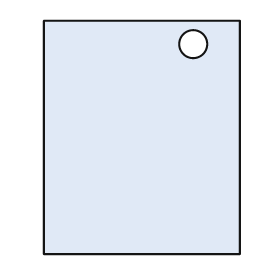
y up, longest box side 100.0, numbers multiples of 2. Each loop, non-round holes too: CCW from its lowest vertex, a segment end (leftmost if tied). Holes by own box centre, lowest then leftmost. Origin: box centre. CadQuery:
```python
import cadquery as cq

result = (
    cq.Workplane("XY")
    .moveTo(-42.0, -50.0)
    .lineTo(42.0, -50.0)
    .lineTo(42.0, 50.0)
    .lineTo(-42.0, 50.0)
    .close()
    .moveTo(22.0, 40.0)
    .circle(6.0)
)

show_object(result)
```